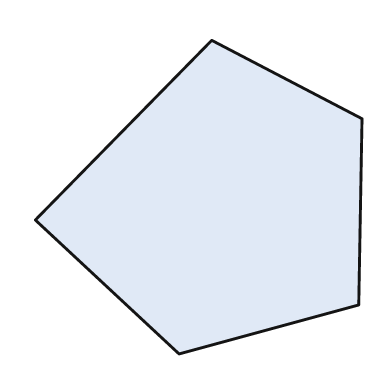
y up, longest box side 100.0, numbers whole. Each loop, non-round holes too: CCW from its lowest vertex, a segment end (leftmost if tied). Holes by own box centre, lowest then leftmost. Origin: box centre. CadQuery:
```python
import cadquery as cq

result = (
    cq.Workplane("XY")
    .moveTo(-6.0, -48.0)
    .lineTo(49.0, -33.0)
    .lineTo(50.0, 24.0)
    .lineTo(4.0, 48.0)
    .lineTo(-50.0, -7.0)
    .close()
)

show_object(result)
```